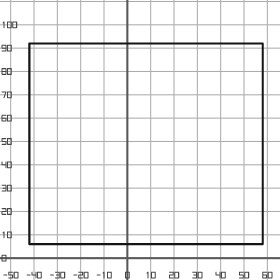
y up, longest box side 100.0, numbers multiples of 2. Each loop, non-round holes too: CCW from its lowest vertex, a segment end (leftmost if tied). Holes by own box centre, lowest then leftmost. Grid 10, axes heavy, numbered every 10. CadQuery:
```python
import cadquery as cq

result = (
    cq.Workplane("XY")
    .moveTo(-42.0, 6.0)
    .lineTo(58.0, 6.0)
    .lineTo(58.0, 92.0)
    .lineTo(-42.0, 92.0)
    .close()
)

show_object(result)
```